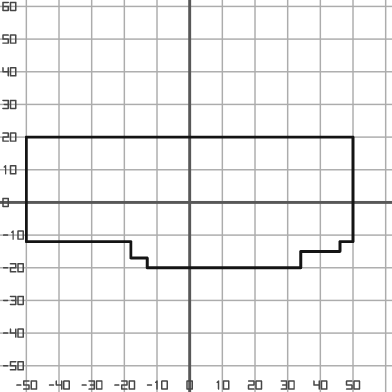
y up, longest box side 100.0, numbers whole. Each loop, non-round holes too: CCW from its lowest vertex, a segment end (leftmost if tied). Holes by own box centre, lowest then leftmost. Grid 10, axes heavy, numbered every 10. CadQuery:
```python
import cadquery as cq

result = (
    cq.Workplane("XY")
    .moveTo(-13.0, -20.0)
    .lineTo(34.0, -20.0)
    .lineTo(34.0, -15.0)
    .lineTo(46.0, -15.0)
    .lineTo(46.0, -12.0)
    .lineTo(50.0, -12.0)
    .lineTo(50.0, 20.0)
    .lineTo(-50.0, 20.0)
    .lineTo(-50.0, -12.0)
    .lineTo(-18.0, -12.0)
    .lineTo(-18.0, -17.0)
    .lineTo(-13.0, -17.0)
    .close()
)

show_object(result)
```